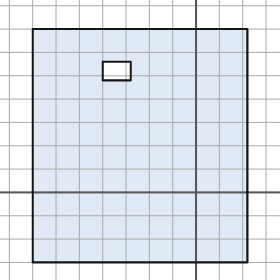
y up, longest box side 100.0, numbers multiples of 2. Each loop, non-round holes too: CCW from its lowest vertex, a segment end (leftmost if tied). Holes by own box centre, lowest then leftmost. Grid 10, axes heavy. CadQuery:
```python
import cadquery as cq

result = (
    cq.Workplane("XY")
    .moveTo(-70.0, -30.0)
    .lineTo(22.0, -30.0)
    .lineTo(22.0, 70.0)
    .lineTo(-70.0, 70.0)
    .close()
    .moveTo(-40.0, 48.0)
    .lineTo(-28.0, 48.0)
    .lineTo(-28.0, 56.0)
    .lineTo(-40.0, 56.0)
    .close()
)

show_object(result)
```